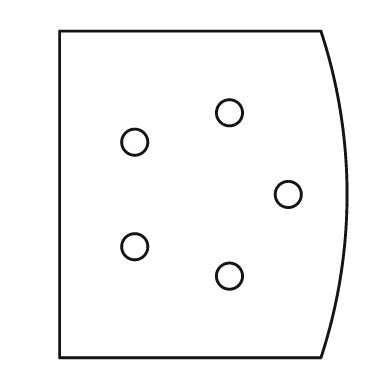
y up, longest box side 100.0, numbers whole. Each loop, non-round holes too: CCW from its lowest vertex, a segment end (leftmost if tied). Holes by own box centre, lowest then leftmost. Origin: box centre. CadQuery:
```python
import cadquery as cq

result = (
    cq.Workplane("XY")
    .moveTo(-44.0, -50.0)
    .lineTo(36.0, -50.0)
    .threePointArc((44.0, 0.0), (36.0, 50.0))
    .lineTo(-44.0, 50.0)
    .close()
    .moveTo(8.0, -25.0)
    .circle(4.0)
    .moveTo(-21.0, -16.0)
    .circle(4.0)
    .moveTo(26.0, 0.0)
    .circle(4.0)
    .moveTo(-21.0, 16.0)
    .circle(4.0)
    .moveTo(8.0, 25.0)
    .circle(4.0)
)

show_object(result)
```